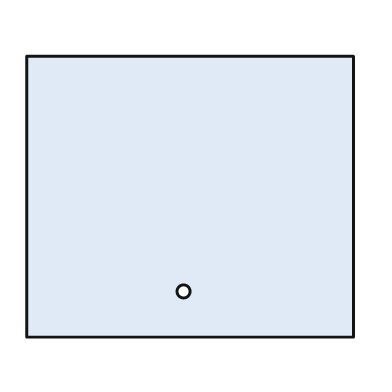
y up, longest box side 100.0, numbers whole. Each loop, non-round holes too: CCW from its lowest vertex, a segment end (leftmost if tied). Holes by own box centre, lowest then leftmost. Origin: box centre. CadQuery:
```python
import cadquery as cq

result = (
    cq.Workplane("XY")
    .moveTo(-50.0, -43.0)
    .lineTo(50.0, -43.0)
    .lineTo(50.0, 43.0)
    .lineTo(-50.0, 43.0)
    .close()
    .moveTo(-2.0, -29.0)
    .circle(2.0)
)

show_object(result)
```